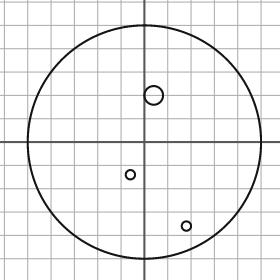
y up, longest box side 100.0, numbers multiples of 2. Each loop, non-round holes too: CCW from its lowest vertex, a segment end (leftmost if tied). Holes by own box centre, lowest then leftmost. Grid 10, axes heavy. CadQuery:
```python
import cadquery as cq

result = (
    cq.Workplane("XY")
    .moveTo(0.0, 0.0)
    .circle(50.0)
    .moveTo(18.0, -36.0)
    .circle(2.0)
    .moveTo(-6.0, -14.0)
    .circle(2.0)
    .moveTo(4.0, 20.0)
    .circle(4.0)
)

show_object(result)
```